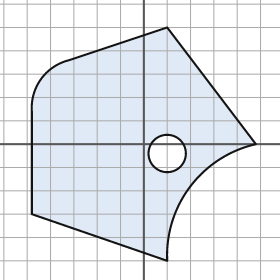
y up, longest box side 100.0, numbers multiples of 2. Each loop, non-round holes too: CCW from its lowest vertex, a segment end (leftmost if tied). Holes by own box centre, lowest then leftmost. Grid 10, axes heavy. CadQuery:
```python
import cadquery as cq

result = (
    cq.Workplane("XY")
    .moveTo(10.0, -50.0)
    .threePointArc((20.0, -18.0), (48.0, 0.0))
    .lineTo(10.0, 50.0)
    .lineTo(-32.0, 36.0)
    .threePointArc((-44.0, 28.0), (-48.0, 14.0))
    .lineTo(-48.0, -30.0)
    .close()
    .moveTo(10.0, -4.0)
    .circle(8.0)
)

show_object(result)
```